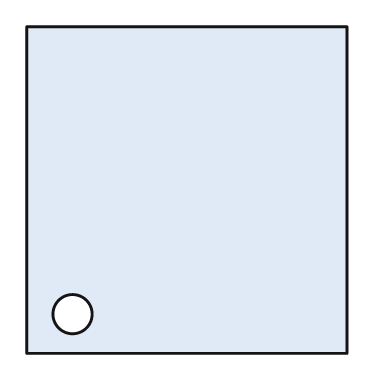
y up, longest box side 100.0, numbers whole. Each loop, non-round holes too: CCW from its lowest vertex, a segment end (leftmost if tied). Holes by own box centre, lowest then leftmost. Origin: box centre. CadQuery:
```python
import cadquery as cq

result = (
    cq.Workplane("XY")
    .moveTo(-49.0, -50.0)
    .lineTo(49.0, -50.0)
    .lineTo(49.0, 50.0)
    .lineTo(-49.0, 50.0)
    .close()
    .moveTo(-35.0, -38.0)
    .circle(6.0)
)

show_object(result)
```